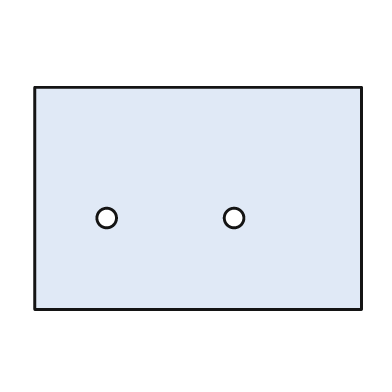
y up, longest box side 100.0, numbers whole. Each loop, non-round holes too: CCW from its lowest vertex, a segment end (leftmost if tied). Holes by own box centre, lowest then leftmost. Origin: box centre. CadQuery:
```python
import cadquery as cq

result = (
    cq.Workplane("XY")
    .moveTo(-50.0, -34.0)
    .lineTo(50.0, -34.0)
    .lineTo(50.0, 34.0)
    .lineTo(-50.0, 34.0)
    .close()
    .moveTo(-28.0, -6.0)
    .circle(3.0)
    .moveTo(11.0, -6.0)
    .circle(3.0)
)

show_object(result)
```